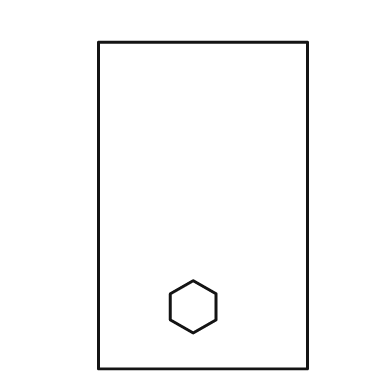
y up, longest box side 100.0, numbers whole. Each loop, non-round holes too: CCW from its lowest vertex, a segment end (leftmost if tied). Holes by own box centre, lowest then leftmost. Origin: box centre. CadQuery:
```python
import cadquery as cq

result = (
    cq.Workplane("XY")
    .moveTo(-32.0, -50.0)
    .lineTo(32.0, -50.0)
    .lineTo(32.0, 50.0)
    .lineTo(-32.0, 50.0)
    .close()
    .moveTo(-3.0, -39.0)
    .lineTo(4.0, -35.0)
    .lineTo(4.0, -27.0)
    .lineTo(-3.0, -23.0)
    .lineTo(-10.0, -27.0)
    .lineTo(-10.0, -35.0)
    .close()
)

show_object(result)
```